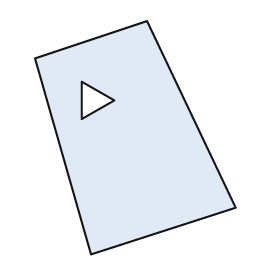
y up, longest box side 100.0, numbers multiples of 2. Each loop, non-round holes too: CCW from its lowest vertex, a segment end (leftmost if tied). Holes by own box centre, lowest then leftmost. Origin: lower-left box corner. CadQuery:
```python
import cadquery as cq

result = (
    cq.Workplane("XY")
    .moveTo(24.0, 0.0)
    .lineTo(86.0, 20.0)
    .lineTo(48.0, 100.0)
    .lineTo(0.0, 84.0)
    .close()
    .moveTo(20.0, 58.0)
    .lineTo(34.0, 66.0)
    .lineTo(20.0, 74.0)
    .close()
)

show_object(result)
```